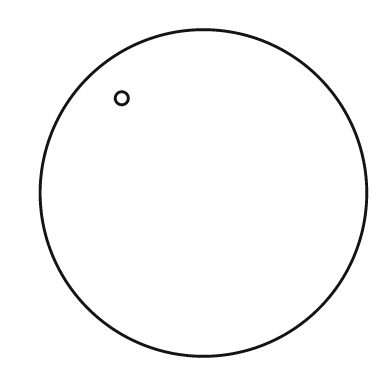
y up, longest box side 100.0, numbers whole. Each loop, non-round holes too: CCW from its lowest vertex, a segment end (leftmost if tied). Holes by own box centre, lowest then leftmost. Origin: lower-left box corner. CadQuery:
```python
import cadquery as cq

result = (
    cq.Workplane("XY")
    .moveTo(50.0, 50.0)
    .circle(50.0)
    .moveTo(25.0, 79.0)
    .circle(2.0)
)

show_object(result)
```